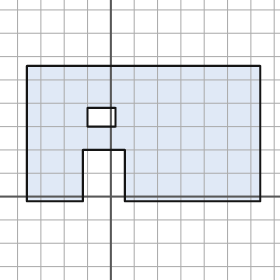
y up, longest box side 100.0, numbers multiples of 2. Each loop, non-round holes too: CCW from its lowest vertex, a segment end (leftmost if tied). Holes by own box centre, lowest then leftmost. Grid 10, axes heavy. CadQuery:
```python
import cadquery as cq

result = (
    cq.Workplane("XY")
    .moveTo(-36.0, -2.0)
    .lineTo(-12.0, -2.0)
    .lineTo(-12.0, 20.0)
    .lineTo(6.0, 20.0)
    .lineTo(6.0, -2.0)
    .lineTo(64.0, -2.0)
    .lineTo(64.0, 56.0)
    .lineTo(-36.0, 56.0)
    .close()
    .moveTo(-10.0, 30.0)
    .lineTo(2.0, 30.0)
    .lineTo(2.0, 38.0)
    .lineTo(-10.0, 38.0)
    .close()
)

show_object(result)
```